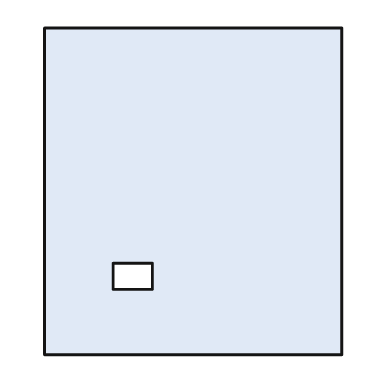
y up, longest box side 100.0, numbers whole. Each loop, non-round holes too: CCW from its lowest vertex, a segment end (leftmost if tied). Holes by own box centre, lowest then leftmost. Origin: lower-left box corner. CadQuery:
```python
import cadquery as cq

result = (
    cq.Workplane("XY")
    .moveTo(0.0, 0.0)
    .lineTo(91.0, 0.0)
    .lineTo(91.0, 100.0)
    .lineTo(0.0, 100.0)
    .close()
    .moveTo(21.0, 20.0)
    .lineTo(33.0, 20.0)
    .lineTo(33.0, 28.0)
    .lineTo(21.0, 28.0)
    .close()
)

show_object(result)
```